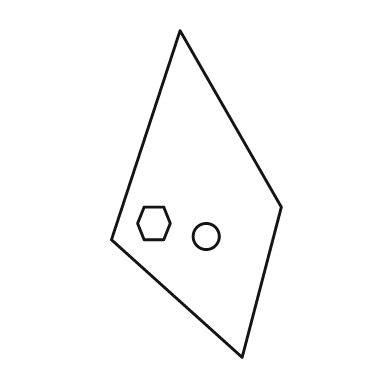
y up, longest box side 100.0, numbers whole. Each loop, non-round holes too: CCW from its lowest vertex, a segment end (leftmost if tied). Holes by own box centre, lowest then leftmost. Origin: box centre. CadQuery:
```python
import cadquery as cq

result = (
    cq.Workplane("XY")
    .moveTo(14.0, -50.0)
    .lineTo(26.0, -4.0)
    .lineTo(-5.0, 50.0)
    .lineTo(-26.0, -14.0)
    .close()
    .moveTo(3.0, -13.0)
    .circle(4.0)
    .moveTo(-16.0, -14.0)
    .lineTo(-10.0, -14.0)
    .lineTo(-8.0, -9.0)
    .lineTo(-10.0, -4.0)
    .lineTo(-16.0, -4.0)
    .lineTo(-18.0, -9.0)
    .close()
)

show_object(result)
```